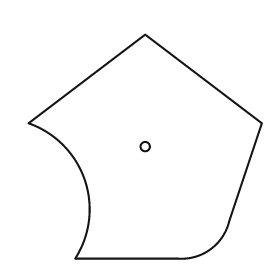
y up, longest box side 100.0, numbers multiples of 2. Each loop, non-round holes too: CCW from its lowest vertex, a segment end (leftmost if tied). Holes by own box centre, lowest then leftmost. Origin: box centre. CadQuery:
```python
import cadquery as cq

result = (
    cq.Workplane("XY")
    .moveTo(-30.0, -48.0)
    .lineTo(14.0, -48.0)
    .threePointArc((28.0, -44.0), (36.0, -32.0))
    .lineTo(50.0, 10.0)
    .lineTo(0.0, 48.0)
    .lineTo(-50.0, 10.0)
    .threePointArc((-26.0, -14.0), (-30.0, -48.0))
    .close()
    .moveTo(0.0, 0.0)
    .circle(2.0)
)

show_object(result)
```